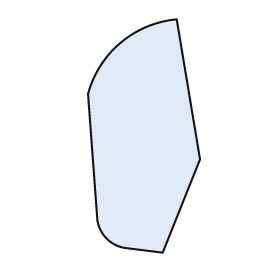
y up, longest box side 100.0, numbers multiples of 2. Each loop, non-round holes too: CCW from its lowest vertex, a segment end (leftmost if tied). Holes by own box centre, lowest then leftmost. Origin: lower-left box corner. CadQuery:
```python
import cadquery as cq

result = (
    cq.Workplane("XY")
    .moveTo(32.0, 0.0)
    .lineTo(48.0, 40.0)
    .lineTo(38.0, 100.0)
    .threePointArc((14.0, 90.0), (0.0, 68.0))
    .lineTo(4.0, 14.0)
    .threePointArc((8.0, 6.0), (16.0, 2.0))
    .close()
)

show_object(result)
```